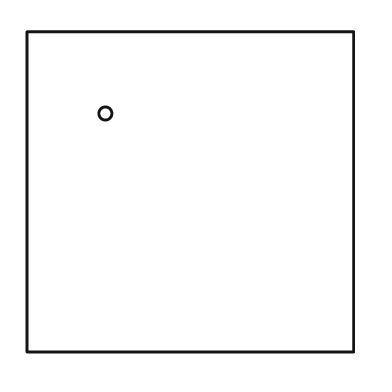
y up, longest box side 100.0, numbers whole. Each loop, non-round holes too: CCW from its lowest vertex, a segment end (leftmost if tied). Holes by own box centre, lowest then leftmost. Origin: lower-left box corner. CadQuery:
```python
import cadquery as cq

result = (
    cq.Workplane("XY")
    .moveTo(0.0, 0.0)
    .lineTo(100.0, 0.0)
    .lineTo(100.0, 98.0)
    .lineTo(0.0, 98.0)
    .close()
    .moveTo(24.0, 73.0)
    .circle(2.0)
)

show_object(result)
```